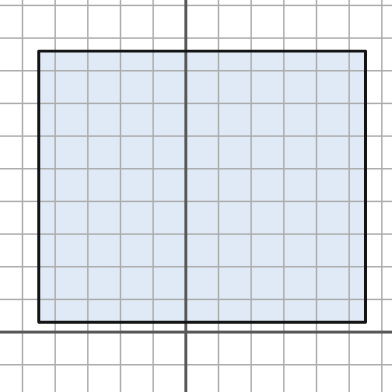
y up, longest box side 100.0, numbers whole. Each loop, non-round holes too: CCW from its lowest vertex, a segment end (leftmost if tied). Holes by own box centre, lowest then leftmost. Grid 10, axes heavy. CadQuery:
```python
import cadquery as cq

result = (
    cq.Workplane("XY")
    .moveTo(-45.0, 3.0)
    .lineTo(55.0, 3.0)
    .lineTo(55.0, 86.0)
    .lineTo(-45.0, 86.0)
    .close()
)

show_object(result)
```